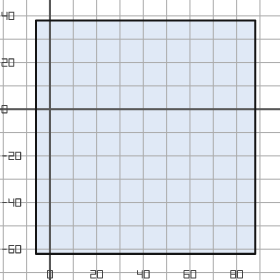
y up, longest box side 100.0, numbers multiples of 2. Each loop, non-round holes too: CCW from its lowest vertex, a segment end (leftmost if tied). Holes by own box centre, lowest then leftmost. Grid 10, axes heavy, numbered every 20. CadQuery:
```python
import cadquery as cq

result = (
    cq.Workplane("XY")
    .moveTo(-6.0, -62.0)
    .lineTo(88.0, -62.0)
    .lineTo(88.0, 38.0)
    .lineTo(-6.0, 38.0)
    .close()
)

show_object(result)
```